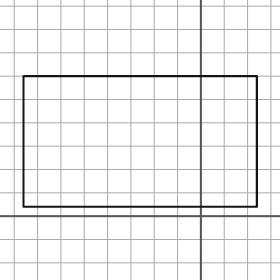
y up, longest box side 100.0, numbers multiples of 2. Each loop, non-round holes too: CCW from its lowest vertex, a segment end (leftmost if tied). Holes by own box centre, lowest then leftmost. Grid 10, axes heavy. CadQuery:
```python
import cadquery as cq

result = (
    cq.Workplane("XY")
    .moveTo(-76.0, 4.0)
    .lineTo(24.0, 4.0)
    .lineTo(24.0, 60.0)
    .lineTo(-76.0, 60.0)
    .close()
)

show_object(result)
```